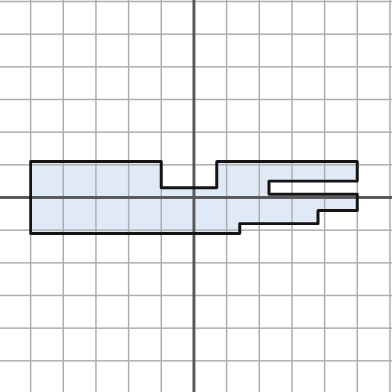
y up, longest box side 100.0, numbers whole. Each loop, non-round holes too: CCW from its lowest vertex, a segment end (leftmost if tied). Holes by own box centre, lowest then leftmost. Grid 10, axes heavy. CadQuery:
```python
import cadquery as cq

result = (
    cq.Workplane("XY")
    .moveTo(-50.0, -11.0)
    .lineTo(14.0, -11.0)
    .lineTo(14.0, -8.0)
    .lineTo(38.0, -8.0)
    .lineTo(38.0, -4.0)
    .lineTo(50.0, -4.0)
    .lineTo(50.0, 1.0)
    .lineTo(23.0, 1.0)
    .lineTo(23.0, 5.0)
    .lineTo(50.0, 5.0)
    .lineTo(50.0, 11.0)
    .lineTo(7.0, 11.0)
    .lineTo(7.0, 3.0)
    .lineTo(-10.0, 3.0)
    .lineTo(-10.0, 11.0)
    .lineTo(-50.0, 11.0)
    .close()
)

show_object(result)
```